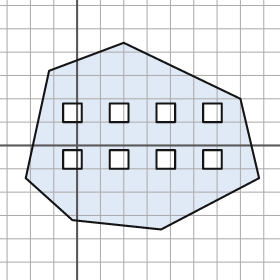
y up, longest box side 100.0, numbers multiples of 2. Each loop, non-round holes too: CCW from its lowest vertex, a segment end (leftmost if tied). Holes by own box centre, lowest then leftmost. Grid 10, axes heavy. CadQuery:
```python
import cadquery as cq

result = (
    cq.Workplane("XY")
    .moveTo(36.0, -36.0)
    .lineTo(78.0, -14.0)
    .lineTo(70.0, 20.0)
    .lineTo(20.0, 44.0)
    .lineTo(-12.0, 32.0)
    .lineTo(-22.0, -14.0)
    .lineTo(-2.0, -32.0)
    .close()
    .moveTo(-6.0, -10.0)
    .lineTo(2.0, -10.0)
    .lineTo(2.0, -2.0)
    .lineTo(-6.0, -2.0)
    .close()
    .moveTo(14.0, -10.0)
    .lineTo(22.0, -10.0)
    .lineTo(22.0, -2.0)
    .lineTo(14.0, -2.0)
    .close()
    .moveTo(34.0, -10.0)
    .lineTo(42.0, -10.0)
    .lineTo(42.0, -2.0)
    .lineTo(34.0, -2.0)
    .close()
    .moveTo(54.0, -10.0)
    .lineTo(62.0, -10.0)
    .lineTo(62.0, -2.0)
    .lineTo(54.0, -2.0)
    .close()
    .moveTo(-6.0, 10.0)
    .lineTo(2.0, 10.0)
    .lineTo(2.0, 18.0)
    .lineTo(-6.0, 18.0)
    .close()
    .moveTo(14.0, 10.0)
    .lineTo(22.0, 10.0)
    .lineTo(22.0, 18.0)
    .lineTo(14.0, 18.0)
    .close()
    .moveTo(34.0, 10.0)
    .lineTo(42.0, 10.0)
    .lineTo(42.0, 18.0)
    .lineTo(34.0, 18.0)
    .close()
    .moveTo(54.0, 10.0)
    .lineTo(62.0, 10.0)
    .lineTo(62.0, 18.0)
    .lineTo(54.0, 18.0)
    .close()
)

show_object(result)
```